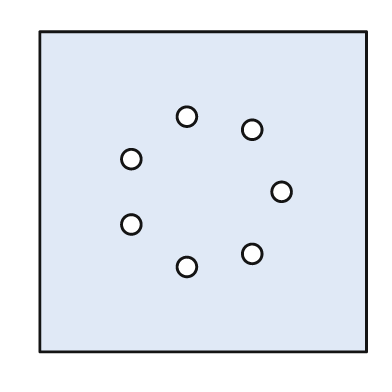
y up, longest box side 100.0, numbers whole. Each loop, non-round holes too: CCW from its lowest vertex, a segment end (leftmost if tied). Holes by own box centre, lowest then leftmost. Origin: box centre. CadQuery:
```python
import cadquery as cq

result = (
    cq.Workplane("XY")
    .moveTo(-50.0, -49.0)
    .lineTo(50.0, -49.0)
    .lineTo(50.0, 49.0)
    .lineTo(-50.0, 49.0)
    .close()
    .moveTo(-5.0, -23.0)
    .circle(3.0)
    .moveTo(15.0, -19.0)
    .circle(3.0)
    .moveTo(-22.0, -10.0)
    .circle(3.0)
    .moveTo(24.0, 0.0)
    .circle(3.0)
    .moveTo(-22.0, 10.0)
    .circle(3.0)
    .moveTo(15.0, 19.0)
    .circle(3.0)
    .moveTo(-5.0, 23.0)
    .circle(3.0)
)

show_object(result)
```